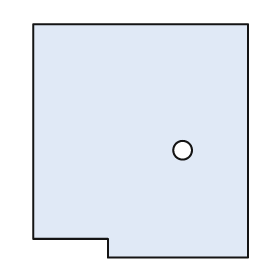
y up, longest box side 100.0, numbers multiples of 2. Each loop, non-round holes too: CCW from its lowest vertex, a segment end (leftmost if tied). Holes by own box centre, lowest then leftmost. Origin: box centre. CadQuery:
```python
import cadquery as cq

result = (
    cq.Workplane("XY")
    .moveTo(-14.0, -50.0)
    .lineTo(46.0, -50.0)
    .lineTo(46.0, 50.0)
    .lineTo(-46.0, 50.0)
    .lineTo(-46.0, -42.0)
    .lineTo(-14.0, -42.0)
    .close()
    .moveTo(18.0, -4.0)
    .circle(4.0)
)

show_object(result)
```